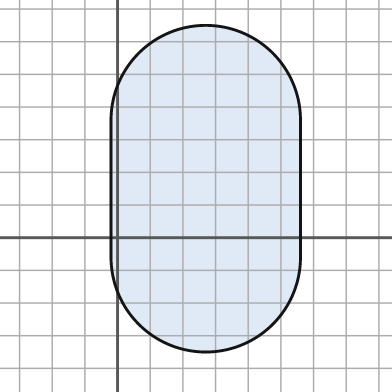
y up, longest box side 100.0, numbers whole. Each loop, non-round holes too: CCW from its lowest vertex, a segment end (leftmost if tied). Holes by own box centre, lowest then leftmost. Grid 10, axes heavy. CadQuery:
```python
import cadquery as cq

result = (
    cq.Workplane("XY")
    .moveTo(-2.0, -6.0)
    .threePointArc((27.0, -35.0), (56.0, -6.0))
    .lineTo(56.0, 36.0)
    .threePointArc((27.0, 65.0), (-2.0, 36.0))
    .close()
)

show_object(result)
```